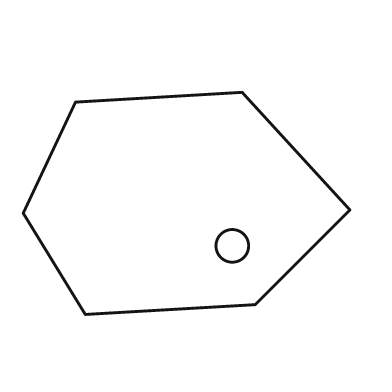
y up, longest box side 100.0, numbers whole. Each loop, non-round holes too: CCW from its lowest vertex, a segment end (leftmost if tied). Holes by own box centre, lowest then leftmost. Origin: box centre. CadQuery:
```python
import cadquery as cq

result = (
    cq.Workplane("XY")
    .moveTo(-31.0, -34.0)
    .lineTo(21.0, -31.0)
    .lineTo(50.0, -2.0)
    .lineTo(17.0, 34.0)
    .lineTo(-34.0, 31.0)
    .lineTo(-50.0, -3.0)
    .close()
    .moveTo(14.0, -13.0)
    .circle(5.0)
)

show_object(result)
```